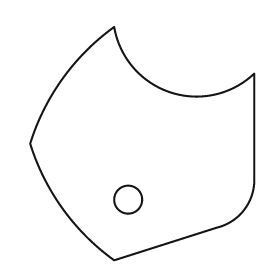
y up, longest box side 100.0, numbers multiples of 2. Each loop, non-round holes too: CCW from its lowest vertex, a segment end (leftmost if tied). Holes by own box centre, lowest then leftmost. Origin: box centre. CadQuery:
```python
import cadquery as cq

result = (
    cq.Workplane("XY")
    .moveTo(-12.0, -50.0)
    .lineTo(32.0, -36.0)
    .threePointArc((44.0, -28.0), (48.0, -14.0))
    .lineTo(48.0, 30.0)
    .threePointArc((12.0, 22.0), (-12.0, 50.0))
    .threePointArc((-34.0, 28.0), (-48.0, 0.0))
    .threePointArc((-34.0, -28.0), (-12.0, -50.0))
    .close()
    .moveTo(-6.0, -24.0)
    .circle(6.0)
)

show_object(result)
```